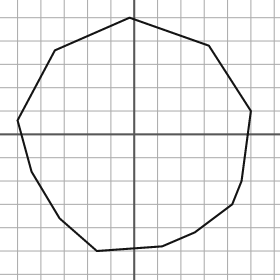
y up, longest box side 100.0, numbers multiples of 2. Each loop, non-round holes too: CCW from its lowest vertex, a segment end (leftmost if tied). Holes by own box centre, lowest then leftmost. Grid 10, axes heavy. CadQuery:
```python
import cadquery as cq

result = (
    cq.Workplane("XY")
    .moveTo(-16.0, -50.0)
    .lineTo(12.0, -48.0)
    .lineTo(26.0, -42.0)
    .lineTo(42.0, -30.0)
    .lineTo(46.0, -20.0)
    .lineTo(50.0, 10.0)
    .lineTo(32.0, 38.0)
    .lineTo(-2.0, 50.0)
    .lineTo(-34.0, 36.0)
    .lineTo(-50.0, 6.0)
    .lineTo(-44.0, -16.0)
    .lineTo(-32.0, -36.0)
    .close()
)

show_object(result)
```